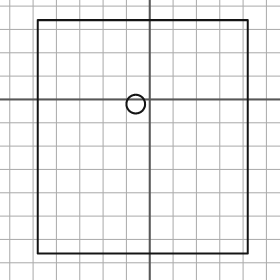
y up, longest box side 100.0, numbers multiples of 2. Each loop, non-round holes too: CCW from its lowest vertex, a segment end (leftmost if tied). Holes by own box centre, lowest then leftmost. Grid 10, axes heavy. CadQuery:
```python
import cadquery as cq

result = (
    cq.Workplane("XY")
    .moveTo(-48.0, -66.0)
    .lineTo(42.0, -66.0)
    .lineTo(42.0, 34.0)
    .lineTo(-48.0, 34.0)
    .close()
    .moveTo(-6.0, -2.0)
    .circle(4.0)
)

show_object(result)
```